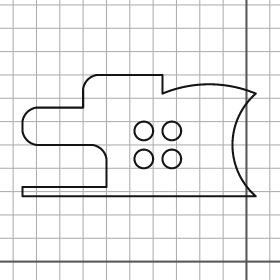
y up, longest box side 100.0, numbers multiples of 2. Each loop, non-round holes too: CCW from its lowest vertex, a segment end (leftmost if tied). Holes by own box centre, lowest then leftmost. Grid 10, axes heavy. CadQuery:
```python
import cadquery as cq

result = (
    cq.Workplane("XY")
    .moveTo(-96.0, 28.0)
    .lineTo(4.0, 28.0)
    .threePointArc((-6.0, 50.0), (4.0, 72.0))
    .threePointArc((-16.0, 76.0), (-36.0, 72.0))
    .lineTo(-36.0, 80.0)
    .lineTo(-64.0, 80.0)
    .threePointArc((-68.0, 78.0), (-70.0, 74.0))
    .lineTo(-70.0, 66.0)
    .lineTo(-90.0, 66.0)
    .threePointArc((-94.0, 64.0), (-96.0, 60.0))
    .lineTo(-96.0, 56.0)
    .threePointArc((-94.0, 52.0), (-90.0, 50.0))
    .lineTo(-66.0, 50.0)
    .threePointArc((-62.0, 48.0), (-60.0, 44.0))
    .lineTo(-60.0, 32.0)
    .lineTo(-96.0, 32.0)
    .close()
    .moveTo(-44.0, 44.0)
    .circle(4.0)
    .moveTo(-32.0, 44.0)
    .circle(4.0)
    .moveTo(-44.0, 56.0)
    .circle(4.0)
    .moveTo(-32.0, 56.0)
    .circle(4.0)
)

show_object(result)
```